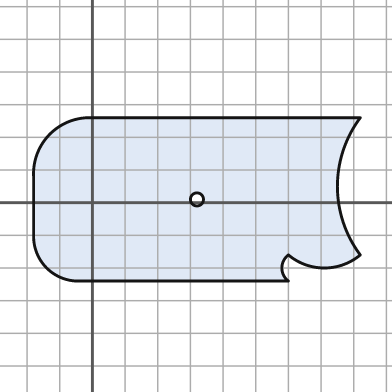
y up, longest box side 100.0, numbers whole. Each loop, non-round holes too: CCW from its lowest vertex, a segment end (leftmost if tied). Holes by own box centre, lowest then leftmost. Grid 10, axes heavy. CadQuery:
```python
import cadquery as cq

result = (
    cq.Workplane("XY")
    .moveTo(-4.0, -24.0)
    .lineTo(60.0, -24.0)
    .threePointArc((58.0, -20.0), (60.0, -16.0))
    .threePointArc((71.0, -20.0), (82.0, -16.0))
    .threePointArc((75.0, 5.0), (82.0, 26.0))
    .lineTo(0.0, 26.0)
    .threePointArc((-13.0, 21.0), (-18.0, 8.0))
    .lineTo(-18.0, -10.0)
    .threePointArc((-14.0, -20.0), (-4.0, -24.0))
    .close()
    .moveTo(32.0, 1.0)
    .circle(2.0)
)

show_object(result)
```